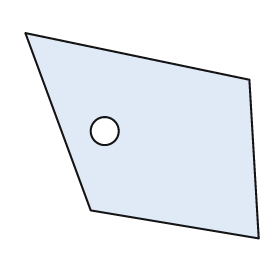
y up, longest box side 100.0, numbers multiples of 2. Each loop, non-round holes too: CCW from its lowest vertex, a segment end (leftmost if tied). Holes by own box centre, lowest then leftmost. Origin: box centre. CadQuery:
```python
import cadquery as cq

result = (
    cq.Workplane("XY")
    .moveTo(50.0, -44.0)
    .lineTo(46.0, 24.0)
    .lineTo(-50.0, 44.0)
    .lineTo(-22.0, -32.0)
    .close()
    .moveTo(-16.0, 2.0)
    .circle(6.0)
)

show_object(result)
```